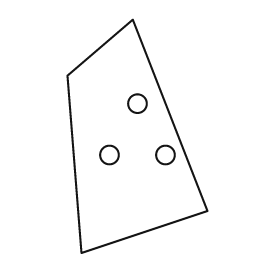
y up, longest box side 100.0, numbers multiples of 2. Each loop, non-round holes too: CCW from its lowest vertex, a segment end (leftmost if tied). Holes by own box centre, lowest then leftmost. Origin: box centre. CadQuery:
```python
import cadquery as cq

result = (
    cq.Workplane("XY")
    .moveTo(-24.0, -50.0)
    .lineTo(30.0, -32.0)
    .lineTo(-2.0, 50.0)
    .lineTo(-30.0, 26.0)
    .close()
    .moveTo(-12.0, -8.0)
    .circle(4.0)
    .moveTo(12.0, -8.0)
    .circle(4.0)
    .moveTo(0.0, 14.0)
    .circle(4.0)
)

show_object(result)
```